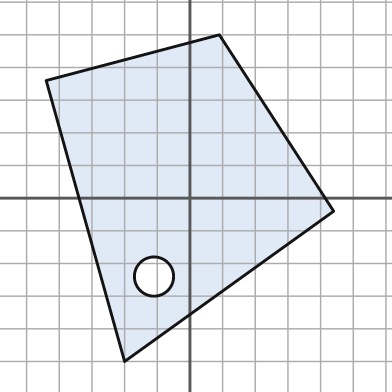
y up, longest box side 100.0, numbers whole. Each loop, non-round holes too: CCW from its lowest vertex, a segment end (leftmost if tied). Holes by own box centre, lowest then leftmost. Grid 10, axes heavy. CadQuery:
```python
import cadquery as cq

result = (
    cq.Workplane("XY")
    .moveTo(-20.0, -50.0)
    .lineTo(44.0, -4.0)
    .lineTo(9.0, 50.0)
    .lineTo(-44.0, 36.0)
    .close()
    .moveTo(-11.0, -24.0)
    .circle(6.0)
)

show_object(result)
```